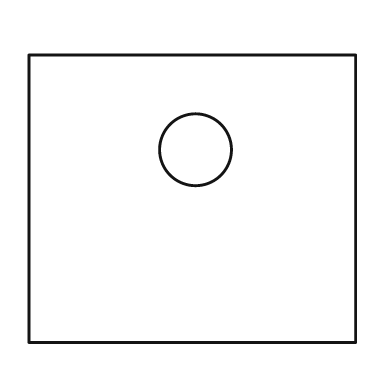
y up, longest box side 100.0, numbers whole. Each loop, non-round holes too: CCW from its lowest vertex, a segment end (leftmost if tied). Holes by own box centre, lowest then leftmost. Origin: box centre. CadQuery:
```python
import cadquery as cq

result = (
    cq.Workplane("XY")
    .moveTo(-50.0, -44.0)
    .lineTo(50.0, -44.0)
    .lineTo(50.0, 44.0)
    .lineTo(-50.0, 44.0)
    .close()
    .moveTo(1.0, 15.0)
    .circle(11.0)
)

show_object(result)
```